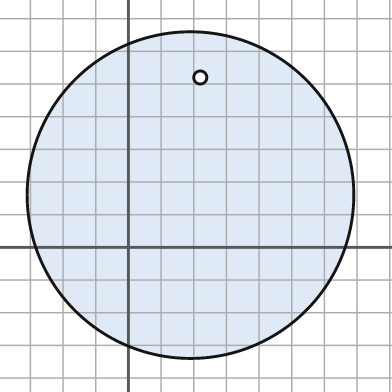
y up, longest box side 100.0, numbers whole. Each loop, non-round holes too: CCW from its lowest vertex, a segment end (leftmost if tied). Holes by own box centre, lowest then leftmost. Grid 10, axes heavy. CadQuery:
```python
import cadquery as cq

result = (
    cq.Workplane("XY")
    .moveTo(19.0, 16.0)
    .circle(50.0)
    .moveTo(22.0, 52.0)
    .circle(2.0)
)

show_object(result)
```